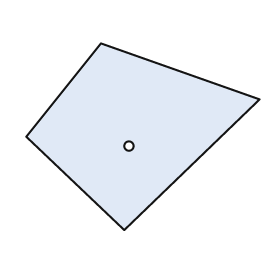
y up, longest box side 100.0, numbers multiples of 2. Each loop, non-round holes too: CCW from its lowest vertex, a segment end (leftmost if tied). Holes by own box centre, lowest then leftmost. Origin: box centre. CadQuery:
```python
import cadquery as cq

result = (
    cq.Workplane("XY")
    .moveTo(-8.0, -40.0)
    .lineTo(50.0, 16.0)
    .lineTo(-18.0, 40.0)
    .lineTo(-50.0, 0.0)
    .close()
    .moveTo(-6.0, -4.0)
    .circle(2.0)
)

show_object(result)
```